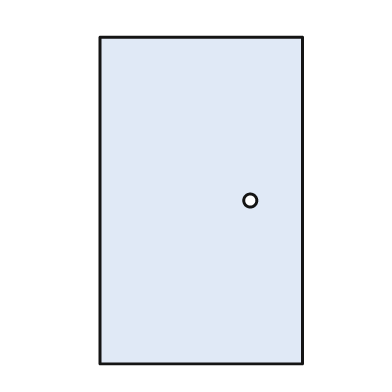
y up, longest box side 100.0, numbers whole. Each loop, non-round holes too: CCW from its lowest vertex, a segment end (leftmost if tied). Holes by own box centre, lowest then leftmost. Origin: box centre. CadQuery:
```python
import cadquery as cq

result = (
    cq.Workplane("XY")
    .moveTo(-31.0, -50.0)
    .lineTo(31.0, -50.0)
    .lineTo(31.0, 50.0)
    .lineTo(-31.0, 50.0)
    .close()
    .moveTo(15.0, 0.0)
    .circle(2.0)
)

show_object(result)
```